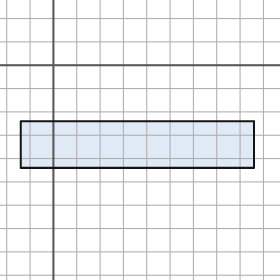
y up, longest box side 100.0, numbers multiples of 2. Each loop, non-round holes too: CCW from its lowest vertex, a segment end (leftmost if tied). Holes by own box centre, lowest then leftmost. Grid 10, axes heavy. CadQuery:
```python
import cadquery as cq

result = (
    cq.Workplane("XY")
    .moveTo(-14.0, -44.0)
    .lineTo(86.0, -44.0)
    .lineTo(86.0, -24.0)
    .lineTo(-14.0, -24.0)
    .close()
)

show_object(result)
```